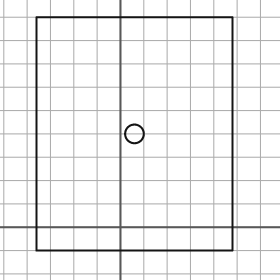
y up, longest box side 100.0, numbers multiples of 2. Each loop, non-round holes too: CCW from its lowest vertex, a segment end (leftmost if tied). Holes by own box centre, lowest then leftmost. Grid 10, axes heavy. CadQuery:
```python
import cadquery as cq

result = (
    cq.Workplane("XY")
    .moveTo(-36.0, -10.0)
    .lineTo(48.0, -10.0)
    .lineTo(48.0, 90.0)
    .lineTo(-36.0, 90.0)
    .close()
    .moveTo(6.0, 40.0)
    .circle(4.0)
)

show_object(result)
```